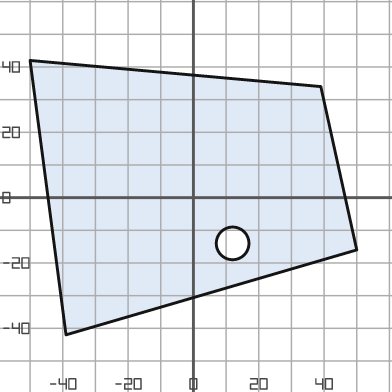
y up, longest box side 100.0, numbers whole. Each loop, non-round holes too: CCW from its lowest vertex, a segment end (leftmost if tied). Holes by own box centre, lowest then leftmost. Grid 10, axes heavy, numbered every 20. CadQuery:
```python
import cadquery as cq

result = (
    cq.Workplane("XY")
    .moveTo(-39.0, -42.0)
    .lineTo(50.0, -16.0)
    .lineTo(39.0, 34.0)
    .lineTo(-50.0, 42.0)
    .close()
    .moveTo(12.0, -14.0)
    .circle(5.0)
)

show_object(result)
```